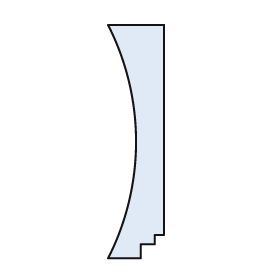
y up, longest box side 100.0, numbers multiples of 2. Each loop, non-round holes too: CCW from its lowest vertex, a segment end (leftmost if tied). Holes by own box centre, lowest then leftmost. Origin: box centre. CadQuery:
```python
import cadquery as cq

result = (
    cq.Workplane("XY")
    .moveTo(-12.0, -50.0)
    .lineTo(2.0, -50.0)
    .lineTo(2.0, -44.0)
    .lineTo(8.0, -44.0)
    .lineTo(8.0, -40.0)
    .lineTo(12.0, -40.0)
    .lineTo(12.0, 50.0)
    .lineTo(-12.0, 50.0)
    .threePointArc((0.0, 0.0), (-12.0, -50.0))
    .close()
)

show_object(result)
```